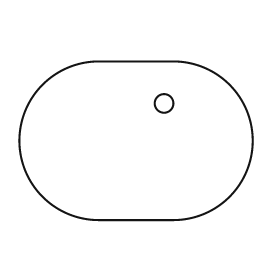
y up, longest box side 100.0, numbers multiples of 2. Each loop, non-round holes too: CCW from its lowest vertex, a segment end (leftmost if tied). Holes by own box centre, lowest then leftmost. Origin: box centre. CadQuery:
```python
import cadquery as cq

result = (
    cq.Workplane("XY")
    .moveTo(-16.0, -34.0)
    .lineTo(16.0, -34.0)
    .threePointArc((50.0, 0.0), (16.0, 34.0))
    .lineTo(-16.0, 34.0)
    .threePointArc((-50.0, 0.0), (-16.0, -34.0))
    .close()
    .moveTo(12.0, 16.0)
    .circle(4.0)
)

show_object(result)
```